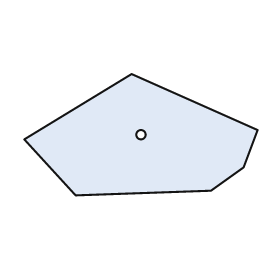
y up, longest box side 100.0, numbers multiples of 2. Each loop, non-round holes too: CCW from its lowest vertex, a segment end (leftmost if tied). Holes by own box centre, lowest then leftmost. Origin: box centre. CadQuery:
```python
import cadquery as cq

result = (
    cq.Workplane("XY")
    .moveTo(-28.0, -26.0)
    .lineTo(30.0, -24.0)
    .lineTo(44.0, -14.0)
    .lineTo(50.0, 2.0)
    .lineTo(-4.0, 26.0)
    .lineTo(-50.0, -2.0)
    .close()
    .moveTo(0.0, 0.0)
    .circle(2.0)
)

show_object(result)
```